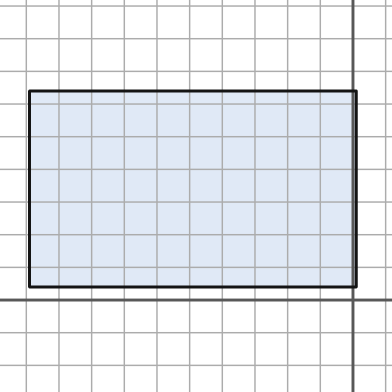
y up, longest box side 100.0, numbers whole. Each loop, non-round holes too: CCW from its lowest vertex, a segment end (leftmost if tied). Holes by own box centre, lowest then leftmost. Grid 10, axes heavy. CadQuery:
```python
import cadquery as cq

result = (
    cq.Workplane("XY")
    .moveTo(-99.0, 4.0)
    .lineTo(1.0, 4.0)
    .lineTo(1.0, 64.0)
    .lineTo(-99.0, 64.0)
    .close()
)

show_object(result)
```